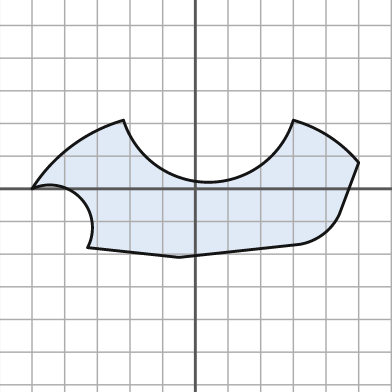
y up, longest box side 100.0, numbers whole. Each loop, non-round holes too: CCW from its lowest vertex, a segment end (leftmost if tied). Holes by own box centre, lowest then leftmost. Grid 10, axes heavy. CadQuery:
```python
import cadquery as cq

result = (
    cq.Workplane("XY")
    .moveTo(-5.0, -21.0)
    .lineTo(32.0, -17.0)
    .threePointArc((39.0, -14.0), (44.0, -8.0))
    .lineTo(50.0, 8.0)
    .threePointArc((41.0, 16.0), (30.0, 21.0))
    .threePointArc((4.0, 2.0), (-22.0, 21.0))
    .threePointArc((-38.0, 13.0), (-50.0, 0.0))
    .threePointArc((-35.0, -3.0), (-33.0, -18.0))
    .close()
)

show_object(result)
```